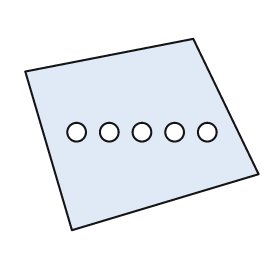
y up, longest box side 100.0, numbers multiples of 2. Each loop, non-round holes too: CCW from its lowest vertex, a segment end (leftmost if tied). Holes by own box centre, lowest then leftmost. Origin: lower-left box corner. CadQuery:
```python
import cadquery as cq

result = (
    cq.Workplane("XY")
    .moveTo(20.0, 0.0)
    .lineTo(100.0, 24.0)
    .lineTo(72.0, 82.0)
    .lineTo(0.0, 68.0)
    .close()
    .moveTo(22.0, 42.0)
    .circle(4.0)
    .moveTo(36.0, 42.0)
    .circle(4.0)
    .moveTo(50.0, 42.0)
    .circle(4.0)
    .moveTo(64.0, 42.0)
    .circle(4.0)
    .moveTo(78.0, 42.0)
    .circle(4.0)
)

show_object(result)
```